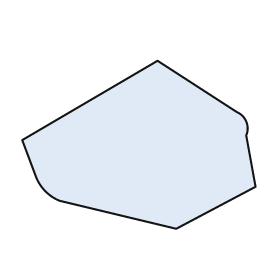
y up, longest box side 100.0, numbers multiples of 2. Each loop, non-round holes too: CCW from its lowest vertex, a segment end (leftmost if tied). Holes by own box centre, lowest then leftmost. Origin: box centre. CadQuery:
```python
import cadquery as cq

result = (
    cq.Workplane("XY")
    .moveTo(16.0, -36.0)
    .lineTo(50.0, -18.0)
    .lineTo(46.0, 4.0)
    .threePointArc((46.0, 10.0), (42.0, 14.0))
    .lineTo(8.0, 36.0)
    .lineTo(-50.0, 2.0)
    .lineTo(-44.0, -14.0)
    .threePointArc((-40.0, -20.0), (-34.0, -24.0))
    .close()
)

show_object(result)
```